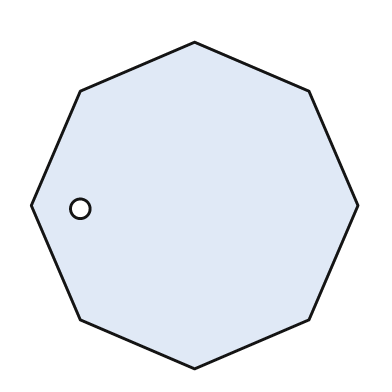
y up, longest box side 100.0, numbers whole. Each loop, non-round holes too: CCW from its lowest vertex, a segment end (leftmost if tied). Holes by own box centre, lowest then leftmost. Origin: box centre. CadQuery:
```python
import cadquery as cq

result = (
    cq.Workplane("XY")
    .moveTo(0.0, -50.0)
    .lineTo(35.0, -35.0)
    .lineTo(50.0, 0.0)
    .lineTo(35.0, 35.0)
    .lineTo(0.0, 50.0)
    .lineTo(-35.0, 35.0)
    .lineTo(-50.0, 0.0)
    .lineTo(-35.0, -35.0)
    .close()
    .moveTo(-35.0, -1.0)
    .circle(3.0)
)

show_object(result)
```